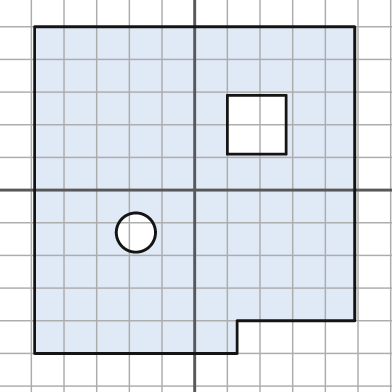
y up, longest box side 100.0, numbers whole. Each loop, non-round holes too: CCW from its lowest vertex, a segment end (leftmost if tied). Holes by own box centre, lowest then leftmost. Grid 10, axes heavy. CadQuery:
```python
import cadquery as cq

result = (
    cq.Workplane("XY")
    .moveTo(-49.0, -50.0)
    .lineTo(13.0, -50.0)
    .lineTo(13.0, -40.0)
    .lineTo(49.0, -40.0)
    .lineTo(49.0, 50.0)
    .lineTo(-49.0, 50.0)
    .close()
    .moveTo(-18.0, -13.0)
    .circle(6.0)
    .moveTo(10.0, 11.0)
    .lineTo(28.0, 11.0)
    .lineTo(28.0, 29.0)
    .lineTo(10.0, 29.0)
    .close()
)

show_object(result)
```